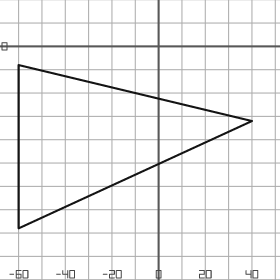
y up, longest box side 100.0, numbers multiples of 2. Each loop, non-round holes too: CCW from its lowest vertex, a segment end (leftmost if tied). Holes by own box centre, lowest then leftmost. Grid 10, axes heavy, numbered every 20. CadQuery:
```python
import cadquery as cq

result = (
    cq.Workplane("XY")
    .moveTo(-60.0, -78.0)
    .lineTo(40.0, -32.0)
    .lineTo(-60.0, -8.0)
    .close()
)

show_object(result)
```